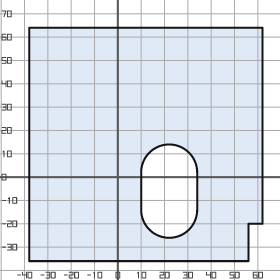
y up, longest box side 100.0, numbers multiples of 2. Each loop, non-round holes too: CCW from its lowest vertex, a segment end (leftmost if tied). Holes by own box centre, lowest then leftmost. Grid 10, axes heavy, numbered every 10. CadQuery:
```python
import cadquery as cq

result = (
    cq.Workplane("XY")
    .moveTo(-38.0, -36.0)
    .lineTo(56.0, -36.0)
    .lineTo(56.0, -20.0)
    .lineTo(62.0, -20.0)
    .lineTo(62.0, 64.0)
    .lineTo(-38.0, 64.0)
    .close()
    .moveTo(10.0, -14.0)
    .threePointArc((22.0, -26.0), (34.0, -14.0))
    .lineTo(34.0, 2.0)
    .threePointArc((22.0, 14.0), (10.0, 2.0))
    .close()
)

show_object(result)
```